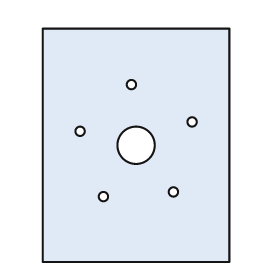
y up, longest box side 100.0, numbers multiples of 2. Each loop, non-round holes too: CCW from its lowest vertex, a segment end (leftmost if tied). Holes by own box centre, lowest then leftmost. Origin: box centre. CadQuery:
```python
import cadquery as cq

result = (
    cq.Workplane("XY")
    .moveTo(-40.0, -50.0)
    .lineTo(40.0, -50.0)
    .lineTo(40.0, 50.0)
    .lineTo(-40.0, 50.0)
    .close()
    .moveTo(-14.0, -22.0)
    .circle(2.0)
    .moveTo(16.0, -20.0)
    .circle(2.0)
    .moveTo(0.0, 0.0)
    .circle(8.0)
    .moveTo(-24.0, 6.0)
    .circle(2.0)
    .moveTo(24.0, 10.0)
    .circle(2.0)
    .moveTo(-2.0, 26.0)
    .circle(2.0)
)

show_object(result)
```